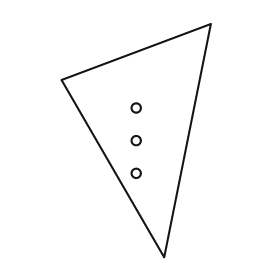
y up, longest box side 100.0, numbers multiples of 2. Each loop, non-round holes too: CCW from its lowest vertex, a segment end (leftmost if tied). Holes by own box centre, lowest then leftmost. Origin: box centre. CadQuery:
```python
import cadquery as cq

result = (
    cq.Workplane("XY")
    .moveTo(12.0, -50.0)
    .lineTo(32.0, 50.0)
    .lineTo(-32.0, 26.0)
    .close()
    .moveTo(0.0, -14.0)
    .circle(2.0)
    .moveTo(0.0, 0.0)
    .circle(2.0)
    .moveTo(0.0, 14.0)
    .circle(2.0)
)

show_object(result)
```